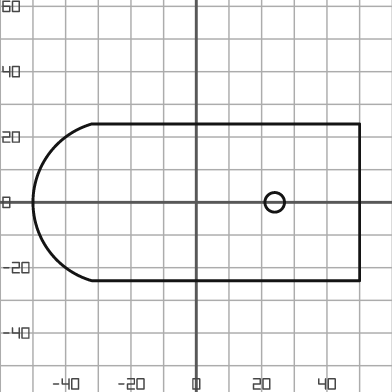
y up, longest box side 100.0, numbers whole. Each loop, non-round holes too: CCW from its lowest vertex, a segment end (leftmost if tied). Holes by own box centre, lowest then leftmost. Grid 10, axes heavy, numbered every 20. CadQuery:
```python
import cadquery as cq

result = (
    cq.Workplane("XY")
    .moveTo(-32.0, -24.0)
    .lineTo(50.0, -24.0)
    .lineTo(50.0, 24.0)
    .lineTo(-32.0, 24.0)
    .threePointArc((-50.0, 0.0), (-32.0, -24.0))
    .close()
    .moveTo(24.0, 0.0)
    .circle(3.0)
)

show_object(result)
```